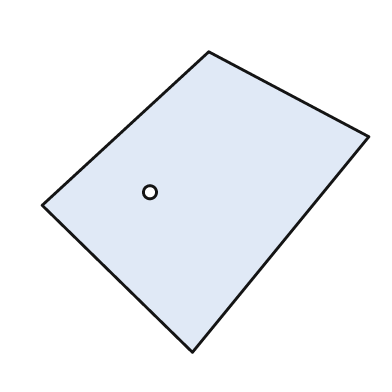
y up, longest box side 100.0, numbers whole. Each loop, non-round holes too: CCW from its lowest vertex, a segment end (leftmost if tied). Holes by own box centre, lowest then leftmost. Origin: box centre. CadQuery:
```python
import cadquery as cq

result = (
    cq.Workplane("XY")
    .moveTo(-4.0, -46.0)
    .lineTo(50.0, 20.0)
    .lineTo(1.0, 46.0)
    .lineTo(-50.0, -1.0)
    .close()
    .moveTo(-17.0, 3.0)
    .circle(2.0)
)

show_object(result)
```